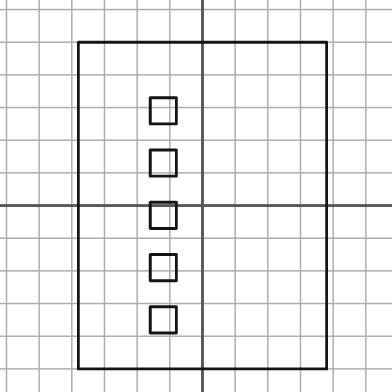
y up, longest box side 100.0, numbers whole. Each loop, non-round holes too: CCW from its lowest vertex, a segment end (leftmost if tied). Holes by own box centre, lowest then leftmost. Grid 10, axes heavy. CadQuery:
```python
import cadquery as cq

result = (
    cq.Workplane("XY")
    .moveTo(-38.0, -50.0)
    .lineTo(38.0, -50.0)
    .lineTo(38.0, 50.0)
    .lineTo(-38.0, 50.0)
    .close()
    .moveTo(-16.0, -39.0)
    .lineTo(-8.0, -39.0)
    .lineTo(-8.0, -31.0)
    .lineTo(-16.0, -31.0)
    .close()
    .moveTo(-16.0, -23.0)
    .lineTo(-8.0, -23.0)
    .lineTo(-8.0, -15.0)
    .lineTo(-16.0, -15.0)
    .close()
    .moveTo(-16.0, -7.0)
    .lineTo(-8.0, -7.0)
    .lineTo(-8.0, 1.0)
    .lineTo(-16.0, 1.0)
    .close()
    .moveTo(-16.0, 9.0)
    .lineTo(-8.0, 9.0)
    .lineTo(-8.0, 17.0)
    .lineTo(-16.0, 17.0)
    .close()
    .moveTo(-16.0, 25.0)
    .lineTo(-8.0, 25.0)
    .lineTo(-8.0, 33.0)
    .lineTo(-16.0, 33.0)
    .close()
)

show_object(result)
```